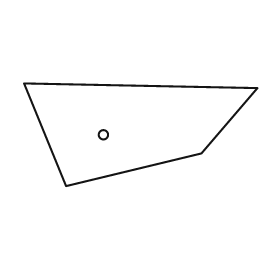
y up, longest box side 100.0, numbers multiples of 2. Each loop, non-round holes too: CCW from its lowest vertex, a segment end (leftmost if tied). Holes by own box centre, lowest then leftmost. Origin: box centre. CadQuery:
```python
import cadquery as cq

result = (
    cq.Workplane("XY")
    .moveTo(-32.0, -22.0)
    .lineTo(26.0, -8.0)
    .lineTo(50.0, 20.0)
    .lineTo(-50.0, 22.0)
    .close()
    .moveTo(-16.0, 0.0)
    .circle(2.0)
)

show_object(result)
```